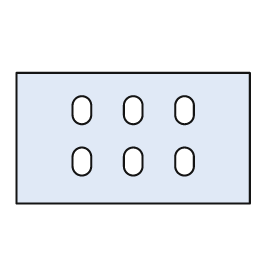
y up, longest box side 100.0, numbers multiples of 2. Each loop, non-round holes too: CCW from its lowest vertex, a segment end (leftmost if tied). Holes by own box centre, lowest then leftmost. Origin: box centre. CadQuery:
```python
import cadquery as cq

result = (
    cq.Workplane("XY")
    .moveTo(-50.0, -28.0)
    .lineTo(50.0, -28.0)
    .lineTo(50.0, 28.0)
    .lineTo(-50.0, 28.0)
    .close()
    .moveTo(-26.0, -12.0)
    .threePointArc((-22.0, -16.0), (-18.0, -12.0))
    .lineTo(-18.0, -8.0)
    .threePointArc((-22.0, -4.0), (-26.0, -8.0))
    .close()
    .moveTo(-4.0, -12.0)
    .threePointArc((0.0, -16.0), (4.0, -12.0))
    .lineTo(4.0, -8.0)
    .threePointArc((0.0, -4.0), (-4.0, -8.0))
    .close()
    .moveTo(18.0, -12.0)
    .threePointArc((22.0, -16.0), (26.0, -12.0))
    .lineTo(26.0, -8.0)
    .threePointArc((22.0, -4.0), (18.0, -8.0))
    .close()
    .moveTo(-26.0, 10.0)
    .threePointArc((-22.0, 6.0), (-18.0, 10.0))
    .lineTo(-18.0, 14.0)
    .threePointArc((-22.0, 18.0), (-26.0, 14.0))
    .close()
    .moveTo(-4.0, 10.0)
    .threePointArc((0.0, 6.0), (4.0, 10.0))
    .lineTo(4.0, 14.0)
    .threePointArc((0.0, 18.0), (-4.0, 14.0))
    .close()
    .moveTo(18.0, 10.0)
    .threePointArc((22.0, 6.0), (26.0, 10.0))
    .lineTo(26.0, 14.0)
    .threePointArc((22.0, 18.0), (18.0, 14.0))
    .close()
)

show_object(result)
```